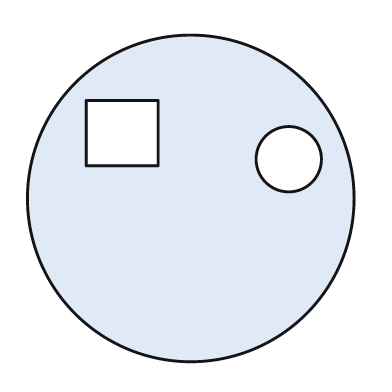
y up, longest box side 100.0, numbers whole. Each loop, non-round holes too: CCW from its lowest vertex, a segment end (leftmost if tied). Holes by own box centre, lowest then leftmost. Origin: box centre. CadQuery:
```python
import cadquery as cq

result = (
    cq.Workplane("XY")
    .moveTo(0.0, 0.0)
    .circle(50.0)
    .moveTo(30.0, 12.0)
    .circle(10.0)
    .moveTo(-32.0, 10.0)
    .lineTo(-10.0, 10.0)
    .lineTo(-10.0, 30.0)
    .lineTo(-32.0, 30.0)
    .close()
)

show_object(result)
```